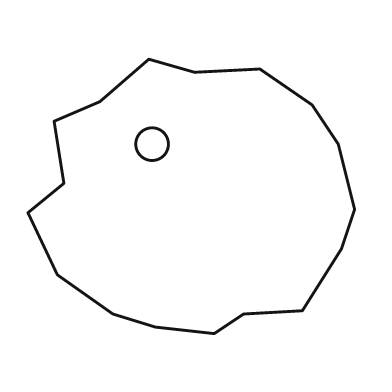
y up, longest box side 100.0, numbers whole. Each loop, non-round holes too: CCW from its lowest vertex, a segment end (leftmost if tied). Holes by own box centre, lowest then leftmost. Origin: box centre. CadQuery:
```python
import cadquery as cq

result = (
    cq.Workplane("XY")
    .moveTo(7.0, -42.0)
    .lineTo(16.0, -36.0)
    .lineTo(34.0, -35.0)
    .lineTo(46.0, -16.0)
    .lineTo(50.0, -4.0)
    .lineTo(45.0, 16.0)
    .lineTo(37.0, 28.0)
    .lineTo(21.0, 39.0)
    .lineTo(1.0, 38.0)
    .lineTo(-13.0, 42.0)
    .lineTo(-28.0, 29.0)
    .lineTo(-42.0, 23.0)
    .lineTo(-39.0, 4.0)
    .lineTo(-50.0, -5.0)
    .lineTo(-41.0, -24.0)
    .lineTo(-24.0, -36.0)
    .lineTo(-11.0, -40.0)
    .close()
    .moveTo(-12.0, 16.0)
    .circle(5.0)
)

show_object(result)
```